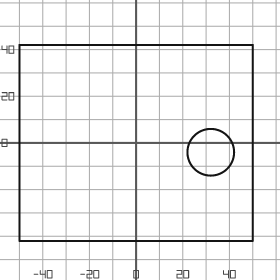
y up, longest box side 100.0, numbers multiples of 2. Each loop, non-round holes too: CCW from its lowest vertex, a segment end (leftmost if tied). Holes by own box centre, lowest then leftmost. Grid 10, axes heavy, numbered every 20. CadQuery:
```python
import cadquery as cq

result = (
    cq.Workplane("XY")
    .moveTo(-50.0, -42.0)
    .lineTo(50.0, -42.0)
    .lineTo(50.0, 42.0)
    .lineTo(-50.0, 42.0)
    .close()
    .moveTo(32.0, -4.0)
    .circle(10.0)
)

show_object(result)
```